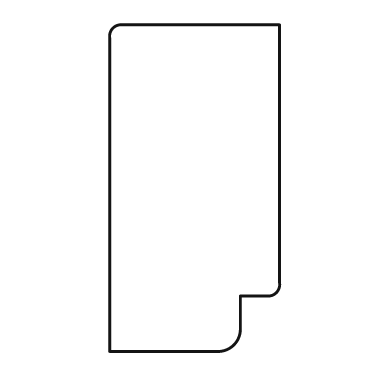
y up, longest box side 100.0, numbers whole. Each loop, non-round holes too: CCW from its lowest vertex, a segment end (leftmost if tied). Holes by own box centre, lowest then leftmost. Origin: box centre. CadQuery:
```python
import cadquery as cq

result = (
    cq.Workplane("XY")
    .moveTo(-26.0, -50.0)
    .lineTo(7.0, -50.0)
    .threePointArc((12.0, -48.0), (14.0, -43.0))
    .lineTo(14.0, -33.0)
    .lineTo(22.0, -33.0)
    .threePointArc((25.0, -32.0), (26.0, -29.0))
    .lineTo(26.0, 50.0)
    .lineTo(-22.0, 50.0)
    .threePointArc((-25.0, 49.0), (-26.0, 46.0))
    .close()
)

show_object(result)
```